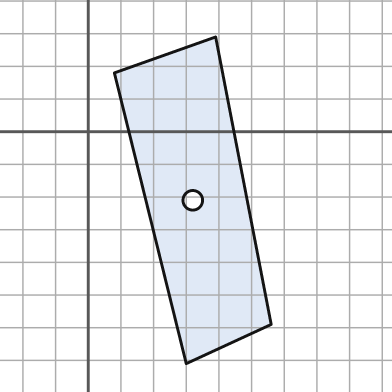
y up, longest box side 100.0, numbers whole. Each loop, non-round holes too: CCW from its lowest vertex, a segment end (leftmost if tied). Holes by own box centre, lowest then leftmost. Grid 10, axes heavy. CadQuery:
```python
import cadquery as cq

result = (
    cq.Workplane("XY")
    .moveTo(30.0, -71.0)
    .lineTo(56.0, -59.0)
    .lineTo(39.0, 29.0)
    .lineTo(8.0, 18.0)
    .close()
    .moveTo(32.0, -21.0)
    .circle(3.0)
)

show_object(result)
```